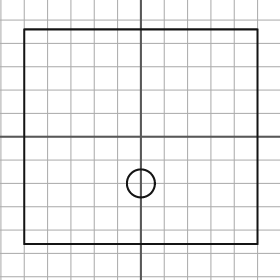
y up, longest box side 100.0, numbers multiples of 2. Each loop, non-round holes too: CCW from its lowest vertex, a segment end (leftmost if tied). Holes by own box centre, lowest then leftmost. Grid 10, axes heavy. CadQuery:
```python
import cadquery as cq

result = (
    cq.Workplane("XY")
    .moveTo(-50.0, -46.0)
    .lineTo(50.0, -46.0)
    .lineTo(50.0, 46.0)
    .lineTo(-50.0, 46.0)
    .close()
    .moveTo(0.0, -20.0)
    .circle(6.0)
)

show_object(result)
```